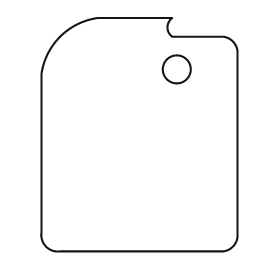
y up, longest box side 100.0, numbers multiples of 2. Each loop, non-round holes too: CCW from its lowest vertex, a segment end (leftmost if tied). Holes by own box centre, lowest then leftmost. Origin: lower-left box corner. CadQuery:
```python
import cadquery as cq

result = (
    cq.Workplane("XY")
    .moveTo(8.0, 0.0)
    .lineTo(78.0, 0.0)
    .threePointArc((82.0, 2.0), (84.0, 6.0))
    .lineTo(84.0, 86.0)
    .threePointArc((82.0, 90.0), (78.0, 92.0))
    .lineTo(56.0, 92.0)
    .threePointArc((54.0, 96.0), (56.0, 100.0))
    .lineTo(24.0, 100.0)
    .threePointArc((8.0, 92.0), (0.0, 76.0))
    .lineTo(0.0, 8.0)
    .threePointArc((2.0, 2.0), (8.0, 0.0))
    .close()
    .moveTo(58.0, 78.0)
    .circle(6.0)
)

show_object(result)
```